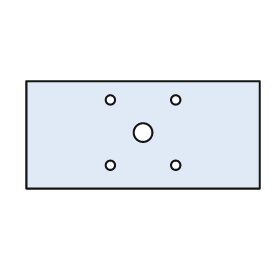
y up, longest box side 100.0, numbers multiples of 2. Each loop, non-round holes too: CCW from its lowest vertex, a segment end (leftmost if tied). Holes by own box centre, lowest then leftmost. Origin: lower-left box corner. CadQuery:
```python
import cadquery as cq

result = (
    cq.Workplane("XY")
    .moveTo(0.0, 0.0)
    .lineTo(100.0, 0.0)
    .lineTo(100.0, 46.0)
    .lineTo(0.0, 46.0)
    .close()
    .moveTo(36.0, 10.0)
    .circle(2.0)
    .moveTo(64.0, 10.0)
    .circle(2.0)
    .moveTo(50.0, 24.0)
    .circle(4.0)
    .moveTo(36.0, 38.0)
    .circle(2.0)
    .moveTo(64.0, 38.0)
    .circle(2.0)
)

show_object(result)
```